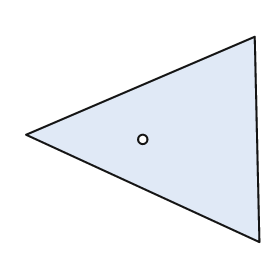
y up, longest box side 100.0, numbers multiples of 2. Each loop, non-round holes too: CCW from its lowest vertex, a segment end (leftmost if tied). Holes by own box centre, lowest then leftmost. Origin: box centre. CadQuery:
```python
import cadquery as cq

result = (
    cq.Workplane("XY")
    .moveTo(50.0, -44.0)
    .lineTo(48.0, 44.0)
    .lineTo(-50.0, 2.0)
    .close()
    .moveTo(0.0, 0.0)
    .circle(2.0)
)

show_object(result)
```